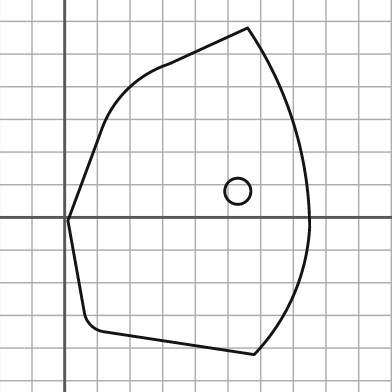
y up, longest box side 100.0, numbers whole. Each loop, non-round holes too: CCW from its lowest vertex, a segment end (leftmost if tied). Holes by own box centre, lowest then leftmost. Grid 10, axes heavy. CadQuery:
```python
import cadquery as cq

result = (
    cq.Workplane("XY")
    .moveTo(58.0, -42.0)
    .threePointArc((70.0, -24.0), (75.0, -3.0))
    .threePointArc((70.0, 29.0), (56.0, 58.0))
    .lineTo(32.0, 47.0)
    .threePointArc((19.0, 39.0), (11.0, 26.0))
    .lineTo(1.0, -1.0)
    .lineTo(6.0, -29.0)
    .threePointArc((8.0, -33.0), (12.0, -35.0))
    .close()
    .moveTo(53.0, 8.0)
    .circle(4.0)
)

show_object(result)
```